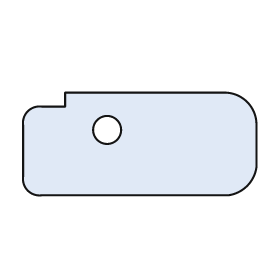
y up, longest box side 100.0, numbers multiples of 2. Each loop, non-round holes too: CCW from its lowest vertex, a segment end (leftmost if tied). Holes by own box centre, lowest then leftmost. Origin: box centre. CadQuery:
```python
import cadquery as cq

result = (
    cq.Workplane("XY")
    .moveTo(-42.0, -22.0)
    .lineTo(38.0, -22.0)
    .threePointArc((46.0, -18.0), (50.0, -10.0))
    .lineTo(50.0, 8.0)
    .threePointArc((46.0, 18.0), (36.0, 22.0))
    .lineTo(-32.0, 22.0)
    .lineTo(-32.0, 16.0)
    .lineTo(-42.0, 16.0)
    .threePointArc((-48.0, 14.0), (-50.0, 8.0))
    .lineTo(-50.0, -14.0)
    .threePointArc((-48.0, -20.0), (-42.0, -22.0))
    .close()
    .moveTo(-14.0, 6.0)
    .circle(6.0)
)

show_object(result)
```